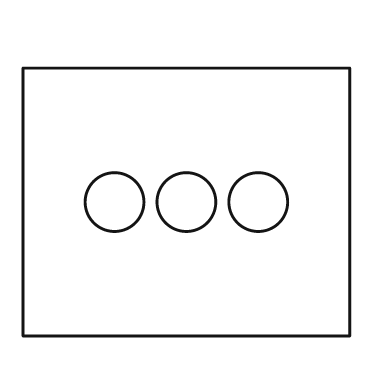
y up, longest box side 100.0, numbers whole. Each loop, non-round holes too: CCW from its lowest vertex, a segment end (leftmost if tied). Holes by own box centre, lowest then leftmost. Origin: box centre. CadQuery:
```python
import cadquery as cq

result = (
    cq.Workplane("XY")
    .moveTo(-50.0, -41.0)
    .lineTo(50.0, -41.0)
    .lineTo(50.0, 41.0)
    .lineTo(-50.0, 41.0)
    .close()
    .moveTo(-22.0, 0.0)
    .circle(9.0)
    .moveTo(0.0, 0.0)
    .circle(9.0)
    .moveTo(22.0, 0.0)
    .circle(9.0)
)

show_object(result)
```